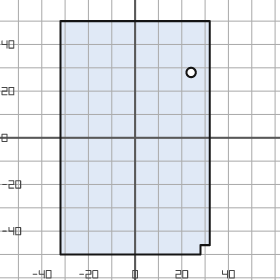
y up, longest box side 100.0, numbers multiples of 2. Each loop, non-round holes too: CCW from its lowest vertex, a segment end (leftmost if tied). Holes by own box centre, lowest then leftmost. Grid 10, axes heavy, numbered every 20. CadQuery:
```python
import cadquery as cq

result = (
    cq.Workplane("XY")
    .moveTo(-32.0, -50.0)
    .lineTo(28.0, -50.0)
    .lineTo(28.0, -46.0)
    .lineTo(32.0, -46.0)
    .lineTo(32.0, 50.0)
    .lineTo(-32.0, 50.0)
    .close()
    .moveTo(24.0, 28.0)
    .circle(2.0)
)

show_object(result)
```